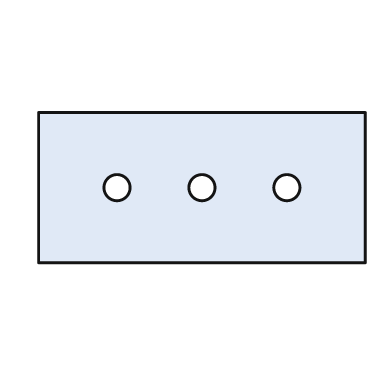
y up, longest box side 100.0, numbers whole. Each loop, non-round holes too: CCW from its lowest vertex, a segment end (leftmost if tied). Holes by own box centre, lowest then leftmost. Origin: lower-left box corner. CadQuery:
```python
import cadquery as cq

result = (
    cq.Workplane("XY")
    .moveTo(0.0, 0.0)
    .lineTo(100.0, 0.0)
    .lineTo(100.0, 46.0)
    .lineTo(0.0, 46.0)
    .close()
    .moveTo(24.0, 23.0)
    .circle(4.0)
    .moveTo(50.0, 23.0)
    .circle(4.0)
    .moveTo(76.0, 23.0)
    .circle(4.0)
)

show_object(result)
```